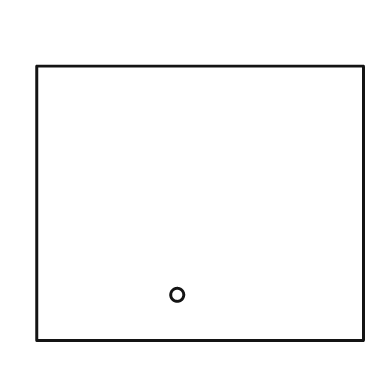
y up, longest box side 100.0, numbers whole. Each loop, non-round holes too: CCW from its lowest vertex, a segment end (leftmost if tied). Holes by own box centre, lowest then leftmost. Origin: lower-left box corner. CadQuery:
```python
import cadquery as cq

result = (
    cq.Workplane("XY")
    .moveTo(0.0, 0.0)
    .lineTo(100.0, 0.0)
    .lineTo(100.0, 84.0)
    .lineTo(0.0, 84.0)
    .close()
    .moveTo(43.0, 14.0)
    .circle(2.0)
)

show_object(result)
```